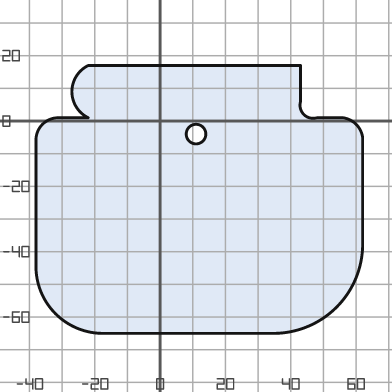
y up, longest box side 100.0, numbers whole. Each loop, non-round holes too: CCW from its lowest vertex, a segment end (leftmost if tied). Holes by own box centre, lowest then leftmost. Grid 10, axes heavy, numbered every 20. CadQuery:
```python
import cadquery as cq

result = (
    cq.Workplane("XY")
    .moveTo(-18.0, -65.0)
    .lineTo(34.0, -65.0)
    .threePointArc((54.0, -57.0), (62.0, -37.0))
    .lineTo(62.0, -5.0)
    .threePointArc((60.0, -1.0), (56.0, 1.0))
    .lineTo(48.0, 1.0)
    .threePointArc((44.0, 2.0), (43.0, 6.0))
    .lineTo(43.0, 17.0)
    .lineTo(-22.0, 17.0)
    .threePointArc((-27.0, 9.0), (-22.0, 1.0))
    .lineTo(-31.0, 1.0)
    .threePointArc((-36.0, -1.0), (-38.0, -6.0))
    .lineTo(-38.0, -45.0)
    .threePointArc((-32.0, -59.0), (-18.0, -65.0))
    .close()
    .moveTo(11.0, -4.0)
    .circle(3.0)
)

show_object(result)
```